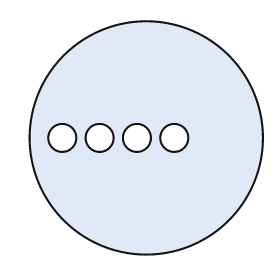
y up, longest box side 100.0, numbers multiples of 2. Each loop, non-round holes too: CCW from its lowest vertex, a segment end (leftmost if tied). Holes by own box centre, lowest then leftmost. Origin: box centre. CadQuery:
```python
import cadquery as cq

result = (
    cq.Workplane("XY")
    .moveTo(0.0, 0.0)
    .circle(50.0)
    .moveTo(-36.0, 0.0)
    .circle(6.0)
    .moveTo(-20.0, 0.0)
    .circle(6.0)
    .moveTo(-4.0, 0.0)
    .circle(6.0)
    .moveTo(12.0, 0.0)
    .circle(6.0)
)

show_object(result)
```